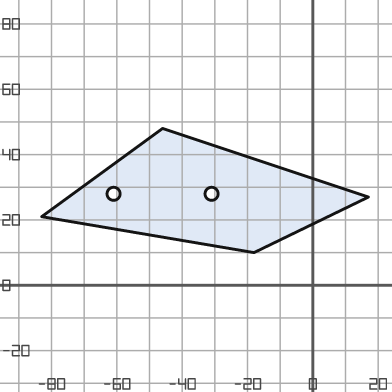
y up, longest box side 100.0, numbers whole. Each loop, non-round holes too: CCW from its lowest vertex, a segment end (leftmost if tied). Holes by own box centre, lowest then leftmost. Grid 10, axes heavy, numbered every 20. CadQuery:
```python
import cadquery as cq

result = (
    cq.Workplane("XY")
    .moveTo(-18.0, 10.0)
    .lineTo(17.0, 27.0)
    .lineTo(-46.0, 48.0)
    .lineTo(-83.0, 21.0)
    .close()
    .moveTo(-61.0, 28.0)
    .circle(2.0)
    .moveTo(-31.0, 28.0)
    .circle(2.0)
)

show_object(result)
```